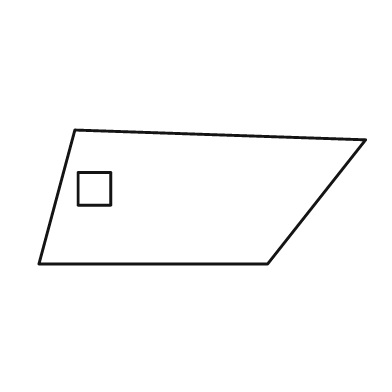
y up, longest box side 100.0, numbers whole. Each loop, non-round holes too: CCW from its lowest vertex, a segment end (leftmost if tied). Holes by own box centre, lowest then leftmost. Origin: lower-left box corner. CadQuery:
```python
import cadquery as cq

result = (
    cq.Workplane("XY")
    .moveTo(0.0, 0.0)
    .lineTo(70.0, 0.0)
    .lineTo(100.0, 38.0)
    .lineTo(11.0, 41.0)
    .close()
    .moveTo(12.0, 18.0)
    .lineTo(22.0, 18.0)
    .lineTo(22.0, 28.0)
    .lineTo(12.0, 28.0)
    .close()
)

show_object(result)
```